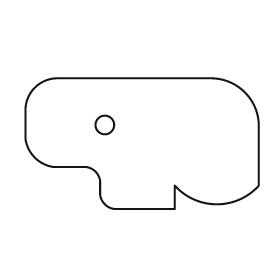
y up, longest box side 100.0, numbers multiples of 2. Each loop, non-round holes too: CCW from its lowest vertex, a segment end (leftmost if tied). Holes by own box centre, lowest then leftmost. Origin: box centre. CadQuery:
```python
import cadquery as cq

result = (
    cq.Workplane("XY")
    .moveTo(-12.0, -28.0)
    .lineTo(14.0, -28.0)
    .lineTo(14.0, -18.0)
    .threePointArc((32.0, -26.0), (50.0, -18.0))
    .lineTo(50.0, 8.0)
    .threePointArc((44.0, 22.0), (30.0, 28.0))
    .lineTo(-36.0, 28.0)
    .threePointArc((-46.0, 24.0), (-50.0, 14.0))
    .lineTo(-50.0, 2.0)
    .threePointArc((-46.0, -6.0), (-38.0, -10.0))
    .lineTo(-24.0, -10.0)
    .threePointArc((-20.0, -12.0), (-18.0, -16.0))
    .lineTo(-18.0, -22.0)
    .threePointArc((-16.0, -26.0), (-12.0, -28.0))
    .close()
    .moveTo(-16.0, 8.0)
    .circle(4.0)
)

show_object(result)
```